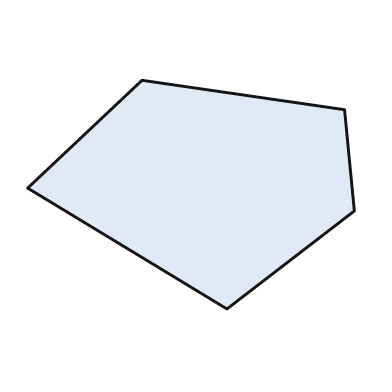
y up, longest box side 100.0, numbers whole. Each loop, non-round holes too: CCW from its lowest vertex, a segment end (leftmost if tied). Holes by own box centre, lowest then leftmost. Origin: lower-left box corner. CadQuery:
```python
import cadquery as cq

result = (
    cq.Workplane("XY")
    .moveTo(61.0, 0.0)
    .lineTo(100.0, 30.0)
    .lineTo(97.0, 61.0)
    .lineTo(35.0, 70.0)
    .lineTo(0.0, 37.0)
    .close()
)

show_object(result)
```